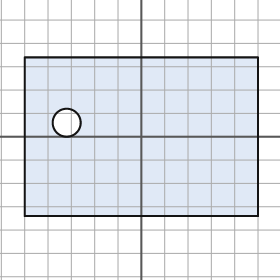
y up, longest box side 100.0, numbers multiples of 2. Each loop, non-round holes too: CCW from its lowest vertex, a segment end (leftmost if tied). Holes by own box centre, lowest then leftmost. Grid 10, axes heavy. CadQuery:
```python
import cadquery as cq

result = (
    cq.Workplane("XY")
    .moveTo(-50.0, -34.0)
    .lineTo(50.0, -34.0)
    .lineTo(50.0, 34.0)
    .lineTo(-50.0, 34.0)
    .close()
    .moveTo(-32.0, 6.0)
    .circle(6.0)
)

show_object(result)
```